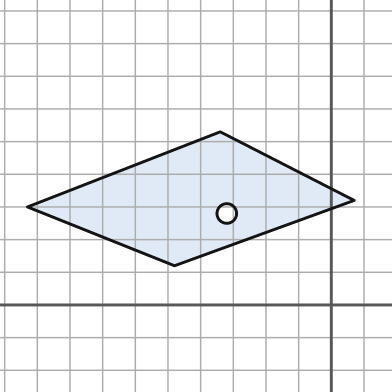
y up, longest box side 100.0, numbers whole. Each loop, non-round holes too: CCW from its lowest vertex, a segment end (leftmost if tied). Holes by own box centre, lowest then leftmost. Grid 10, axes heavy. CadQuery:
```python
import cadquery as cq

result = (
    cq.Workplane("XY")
    .moveTo(-48.0, 12.0)
    .lineTo(7.0, 32.0)
    .lineTo(-34.0, 53.0)
    .lineTo(-93.0, 30.0)
    .close()
    .moveTo(-32.0, 28.0)
    .circle(3.0)
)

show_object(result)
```